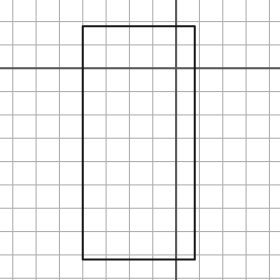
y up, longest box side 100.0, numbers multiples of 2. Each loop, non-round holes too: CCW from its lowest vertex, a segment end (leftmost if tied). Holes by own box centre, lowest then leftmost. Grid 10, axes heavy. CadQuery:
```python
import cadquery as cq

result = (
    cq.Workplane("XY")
    .moveTo(-40.0, -82.0)
    .lineTo(8.0, -82.0)
    .lineTo(8.0, 18.0)
    .lineTo(-40.0, 18.0)
    .close()
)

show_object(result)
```